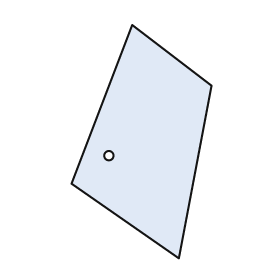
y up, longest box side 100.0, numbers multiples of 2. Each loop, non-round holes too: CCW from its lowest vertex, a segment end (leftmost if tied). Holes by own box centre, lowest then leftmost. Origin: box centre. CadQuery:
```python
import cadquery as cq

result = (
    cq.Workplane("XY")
    .moveTo(16.0, -50.0)
    .lineTo(30.0, 24.0)
    .lineTo(-4.0, 50.0)
    .lineTo(-30.0, -18.0)
    .close()
    .moveTo(-14.0, -6.0)
    .circle(2.0)
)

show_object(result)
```